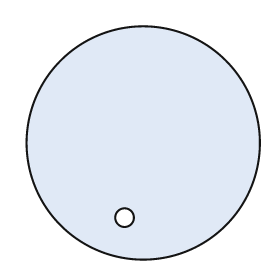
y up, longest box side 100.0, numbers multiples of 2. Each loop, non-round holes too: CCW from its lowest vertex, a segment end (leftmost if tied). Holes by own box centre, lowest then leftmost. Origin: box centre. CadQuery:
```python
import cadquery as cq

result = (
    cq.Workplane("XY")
    .moveTo(0.0, 0.0)
    .circle(50.0)
    .moveTo(-8.0, -32.0)
    .circle(4.0)
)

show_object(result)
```